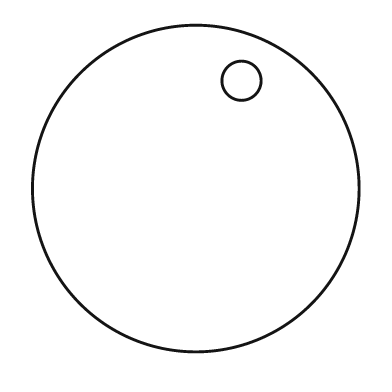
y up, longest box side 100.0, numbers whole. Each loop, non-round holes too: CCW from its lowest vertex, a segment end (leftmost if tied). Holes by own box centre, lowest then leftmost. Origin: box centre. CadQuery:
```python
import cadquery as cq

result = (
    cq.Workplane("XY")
    .moveTo(0.0, 0.0)
    .circle(50.0)
    .moveTo(14.0, 33.0)
    .circle(6.0)
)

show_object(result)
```